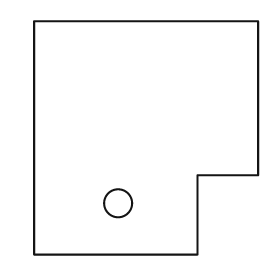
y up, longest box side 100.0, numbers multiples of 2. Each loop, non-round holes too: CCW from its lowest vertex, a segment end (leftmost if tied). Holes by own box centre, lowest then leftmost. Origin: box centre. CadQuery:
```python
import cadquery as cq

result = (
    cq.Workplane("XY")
    .moveTo(-48.0, -50.0)
    .lineTo(22.0, -50.0)
    .lineTo(22.0, -16.0)
    .lineTo(48.0, -16.0)
    .lineTo(48.0, 50.0)
    .lineTo(-48.0, 50.0)
    .close()
    .moveTo(-12.0, -28.0)
    .circle(6.0)
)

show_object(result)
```